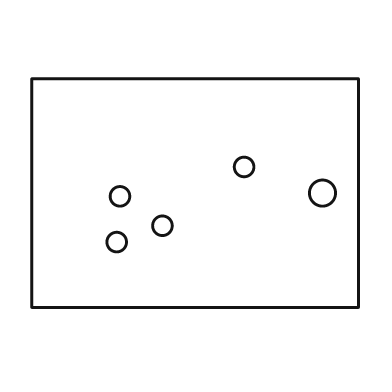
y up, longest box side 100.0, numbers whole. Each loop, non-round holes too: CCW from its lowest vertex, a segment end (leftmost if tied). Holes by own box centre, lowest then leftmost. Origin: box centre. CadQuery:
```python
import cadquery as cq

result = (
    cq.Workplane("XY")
    .moveTo(-50.0, -35.0)
    .lineTo(50.0, -35.0)
    .lineTo(50.0, 35.0)
    .lineTo(-50.0, 35.0)
    .close()
    .moveTo(-24.0, -15.0)
    .circle(3.0)
    .moveTo(-10.0, -10.0)
    .circle(3.0)
    .moveTo(-23.0, -1.0)
    .circle(3.0)
    .moveTo(39.0, 0.0)
    .circle(4.0)
    .moveTo(15.0, 8.0)
    .circle(3.0)
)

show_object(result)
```